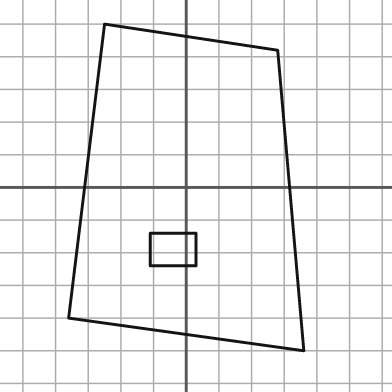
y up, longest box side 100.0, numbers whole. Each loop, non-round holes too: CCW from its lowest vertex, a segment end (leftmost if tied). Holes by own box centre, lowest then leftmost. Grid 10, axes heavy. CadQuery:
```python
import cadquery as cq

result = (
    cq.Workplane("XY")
    .moveTo(36.0, -50.0)
    .lineTo(28.0, 42.0)
    .lineTo(-25.0, 50.0)
    .lineTo(-36.0, -40.0)
    .close()
    .moveTo(-11.0, -24.0)
    .lineTo(3.0, -24.0)
    .lineTo(3.0, -14.0)
    .lineTo(-11.0, -14.0)
    .close()
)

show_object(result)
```